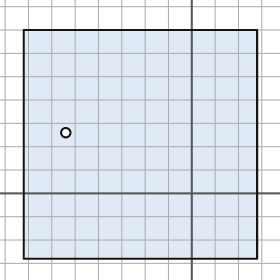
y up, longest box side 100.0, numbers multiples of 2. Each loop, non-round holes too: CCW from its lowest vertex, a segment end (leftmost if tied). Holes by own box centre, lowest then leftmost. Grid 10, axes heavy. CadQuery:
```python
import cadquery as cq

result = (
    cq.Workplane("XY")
    .moveTo(-72.0, -28.0)
    .lineTo(28.0, -28.0)
    .lineTo(28.0, 70.0)
    .lineTo(-72.0, 70.0)
    .close()
    .moveTo(-54.0, 26.0)
    .circle(2.0)
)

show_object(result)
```